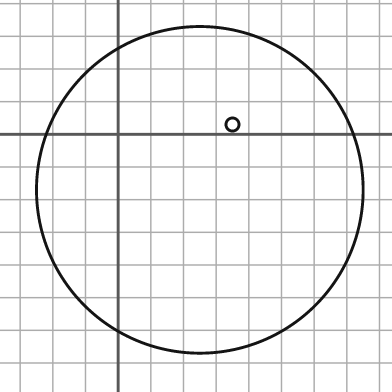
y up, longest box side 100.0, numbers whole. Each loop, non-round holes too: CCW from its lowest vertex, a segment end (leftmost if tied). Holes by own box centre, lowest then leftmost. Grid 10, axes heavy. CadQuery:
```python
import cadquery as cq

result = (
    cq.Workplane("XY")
    .moveTo(25.0, -17.0)
    .circle(50.0)
    .moveTo(35.0, 3.0)
    .circle(2.0)
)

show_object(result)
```